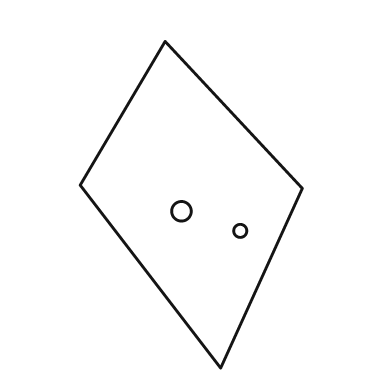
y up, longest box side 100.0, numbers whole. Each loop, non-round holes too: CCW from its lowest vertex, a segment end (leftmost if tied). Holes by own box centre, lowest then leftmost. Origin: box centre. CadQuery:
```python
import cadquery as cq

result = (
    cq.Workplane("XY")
    .moveTo(9.0, -50.0)
    .lineTo(34.0, 5.0)
    .lineTo(-8.0, 50.0)
    .lineTo(-34.0, 6.0)
    .close()
    .moveTo(15.0, -8.0)
    .circle(2.0)
    .moveTo(-3.0, -2.0)
    .circle(3.0)
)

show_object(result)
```